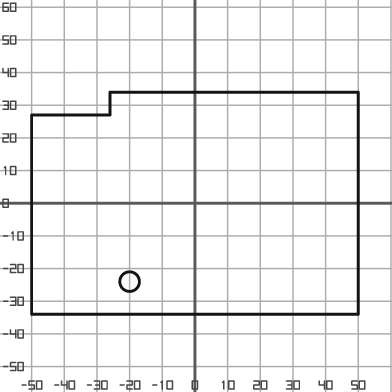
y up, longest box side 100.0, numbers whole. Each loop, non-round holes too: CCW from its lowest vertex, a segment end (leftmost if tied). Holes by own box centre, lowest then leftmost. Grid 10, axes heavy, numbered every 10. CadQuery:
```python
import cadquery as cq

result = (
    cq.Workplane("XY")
    .moveTo(-50.0, -34.0)
    .lineTo(50.0, -34.0)
    .lineTo(50.0, 34.0)
    .lineTo(-26.0, 34.0)
    .lineTo(-26.0, 27.0)
    .lineTo(-50.0, 27.0)
    .close()
    .moveTo(-20.0, -24.0)
    .circle(3.0)
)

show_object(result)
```